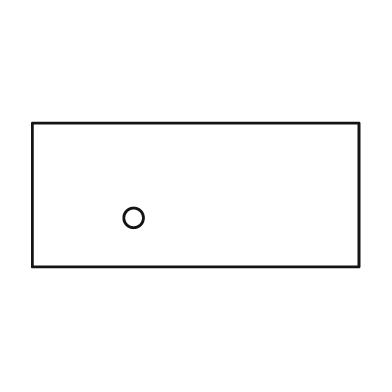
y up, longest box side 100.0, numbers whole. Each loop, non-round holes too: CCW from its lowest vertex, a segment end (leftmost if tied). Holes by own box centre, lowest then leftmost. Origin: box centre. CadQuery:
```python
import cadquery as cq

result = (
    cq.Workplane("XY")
    .moveTo(-50.0, -22.0)
    .lineTo(50.0, -22.0)
    .lineTo(50.0, 22.0)
    .lineTo(-50.0, 22.0)
    .close()
    .moveTo(-19.0, -7.0)
    .circle(3.0)
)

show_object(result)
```